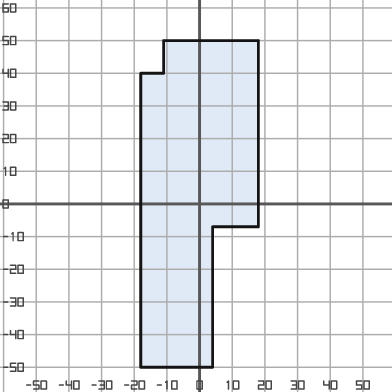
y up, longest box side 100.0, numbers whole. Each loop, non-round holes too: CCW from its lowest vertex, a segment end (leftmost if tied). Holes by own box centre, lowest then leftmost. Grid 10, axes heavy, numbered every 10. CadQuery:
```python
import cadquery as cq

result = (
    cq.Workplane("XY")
    .moveTo(-18.0, -50.0)
    .lineTo(4.0, -50.0)
    .lineTo(4.0, -7.0)
    .lineTo(18.0, -7.0)
    .lineTo(18.0, 50.0)
    .lineTo(-11.0, 50.0)
    .lineTo(-11.0, 40.0)
    .lineTo(-18.0, 40.0)
    .close()
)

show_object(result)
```